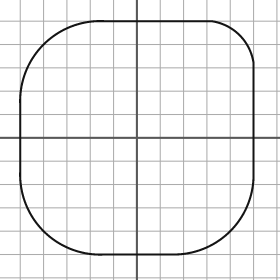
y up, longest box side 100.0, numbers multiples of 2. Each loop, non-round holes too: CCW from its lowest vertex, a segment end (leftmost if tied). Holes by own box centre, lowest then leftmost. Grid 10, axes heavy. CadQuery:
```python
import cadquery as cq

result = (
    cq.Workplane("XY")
    .moveTo(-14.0, -50.0)
    .lineTo(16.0, -50.0)
    .threePointArc((40.0, -40.0), (50.0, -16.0))
    .lineTo(50.0, 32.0)
    .threePointArc((44.0, 44.0), (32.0, 50.0))
    .lineTo(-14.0, 50.0)
    .threePointArc((-40.0, 40.0), (-50.0, 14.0))
    .lineTo(-50.0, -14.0)
    .threePointArc((-40.0, -40.0), (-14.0, -50.0))
    .close()
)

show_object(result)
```